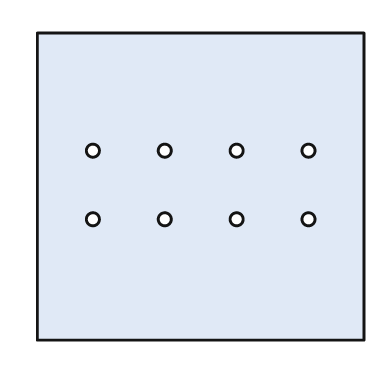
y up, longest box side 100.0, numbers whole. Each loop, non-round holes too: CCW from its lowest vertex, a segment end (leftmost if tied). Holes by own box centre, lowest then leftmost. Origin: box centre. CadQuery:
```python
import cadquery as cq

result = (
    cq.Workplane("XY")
    .moveTo(-50.0, -47.0)
    .lineTo(50.0, -47.0)
    .lineTo(50.0, 47.0)
    .lineTo(-50.0, 47.0)
    .close()
    .moveTo(-33.0, -10.0)
    .circle(2.0)
    .moveTo(-11.0, -10.0)
    .circle(2.0)
    .moveTo(11.0, -10.0)
    .circle(2.0)
    .moveTo(33.0, -10.0)
    .circle(2.0)
    .moveTo(-33.0, 11.0)
    .circle(2.0)
    .moveTo(-11.0, 11.0)
    .circle(2.0)
    .moveTo(11.0, 11.0)
    .circle(2.0)
    .moveTo(33.0, 11.0)
    .circle(2.0)
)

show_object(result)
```